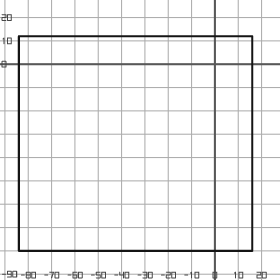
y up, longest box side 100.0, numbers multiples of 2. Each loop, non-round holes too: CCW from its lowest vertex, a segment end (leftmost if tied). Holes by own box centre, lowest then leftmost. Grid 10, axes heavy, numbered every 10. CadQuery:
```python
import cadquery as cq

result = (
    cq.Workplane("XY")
    .moveTo(-84.0, -80.0)
    .lineTo(16.0, -80.0)
    .lineTo(16.0, 12.0)
    .lineTo(-84.0, 12.0)
    .close()
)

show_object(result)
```